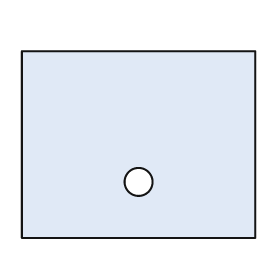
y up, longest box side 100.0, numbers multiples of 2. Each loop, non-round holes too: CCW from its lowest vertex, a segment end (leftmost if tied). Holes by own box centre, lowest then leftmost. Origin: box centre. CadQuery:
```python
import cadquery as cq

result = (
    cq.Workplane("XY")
    .moveTo(-50.0, -40.0)
    .lineTo(50.0, -40.0)
    .lineTo(50.0, 40.0)
    .lineTo(-50.0, 40.0)
    .close()
    .moveTo(0.0, -16.0)
    .circle(6.0)
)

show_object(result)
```